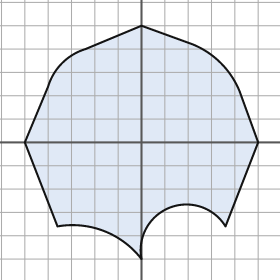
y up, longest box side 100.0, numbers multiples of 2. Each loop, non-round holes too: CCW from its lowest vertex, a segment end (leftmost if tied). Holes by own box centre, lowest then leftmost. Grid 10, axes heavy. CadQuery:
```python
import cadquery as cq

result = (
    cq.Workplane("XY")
    .moveTo(0.0, -50.0)
    .threePointArc((12.0, -28.0), (36.0, -36.0))
    .lineTo(50.0, 0.0)
    .lineTo(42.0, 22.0)
    .threePointArc((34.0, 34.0), (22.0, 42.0))
    .lineTo(0.0, 50.0)
    .lineTo(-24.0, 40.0)
    .threePointArc((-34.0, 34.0), (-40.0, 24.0))
    .lineTo(-50.0, 0.0)
    .lineTo(-36.0, -36.0)
    .threePointArc((-16.0, -38.0), (0.0, -50.0))
    .close()
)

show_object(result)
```